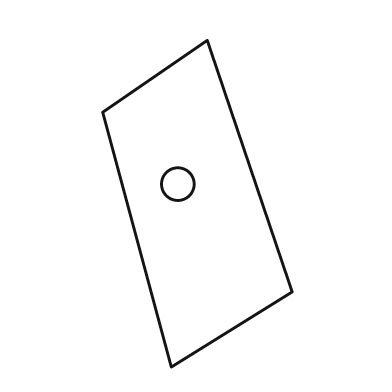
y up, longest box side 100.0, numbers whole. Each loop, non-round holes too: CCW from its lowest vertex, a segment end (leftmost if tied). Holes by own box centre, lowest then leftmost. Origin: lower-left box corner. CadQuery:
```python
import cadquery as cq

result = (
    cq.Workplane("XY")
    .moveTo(21.0, 0.0)
    .lineTo(58.0, 23.0)
    .lineTo(32.0, 100.0)
    .lineTo(0.0, 78.0)
    .close()
    .moveTo(23.0, 56.0)
    .circle(5.0)
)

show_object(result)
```